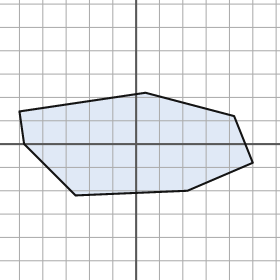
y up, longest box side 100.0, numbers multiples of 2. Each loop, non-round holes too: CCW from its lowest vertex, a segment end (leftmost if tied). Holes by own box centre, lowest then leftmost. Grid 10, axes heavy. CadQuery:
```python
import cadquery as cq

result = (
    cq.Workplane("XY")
    .moveTo(-26.0, -22.0)
    .lineTo(22.0, -20.0)
    .lineTo(50.0, -8.0)
    .lineTo(42.0, 12.0)
    .lineTo(4.0, 22.0)
    .lineTo(-50.0, 14.0)
    .lineTo(-48.0, 0.0)
    .close()
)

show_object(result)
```